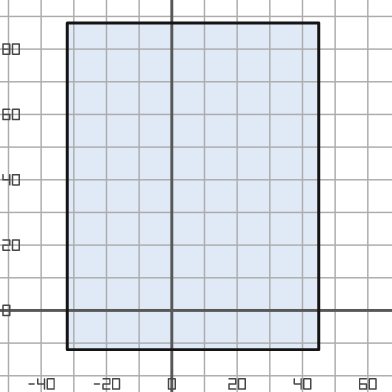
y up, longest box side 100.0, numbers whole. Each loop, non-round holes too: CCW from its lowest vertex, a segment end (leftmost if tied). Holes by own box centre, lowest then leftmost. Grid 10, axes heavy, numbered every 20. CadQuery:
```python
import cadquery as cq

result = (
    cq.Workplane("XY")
    .moveTo(-32.0, -12.0)
    .lineTo(45.0, -12.0)
    .lineTo(45.0, 88.0)
    .lineTo(-32.0, 88.0)
    .close()
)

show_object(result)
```